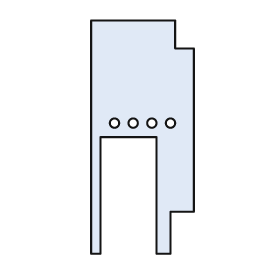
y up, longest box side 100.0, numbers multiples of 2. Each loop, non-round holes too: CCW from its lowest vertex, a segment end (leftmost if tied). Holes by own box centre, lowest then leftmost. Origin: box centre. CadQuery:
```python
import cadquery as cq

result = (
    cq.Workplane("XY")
    .moveTo(-22.0, -50.0)
    .lineTo(-18.0, -50.0)
    .lineTo(-18.0, 0.0)
    .lineTo(6.0, 0.0)
    .lineTo(6.0, -50.0)
    .lineTo(12.0, -50.0)
    .lineTo(12.0, -32.0)
    .lineTo(22.0, -32.0)
    .lineTo(22.0, 38.0)
    .lineTo(14.0, 38.0)
    .lineTo(14.0, 50.0)
    .lineTo(-22.0, 50.0)
    .close()
    .moveTo(-12.0, 6.0)
    .circle(2.0)
    .moveTo(-4.0, 6.0)
    .circle(2.0)
    .moveTo(4.0, 6.0)
    .circle(2.0)
    .moveTo(12.0, 6.0)
    .circle(2.0)
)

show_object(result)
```